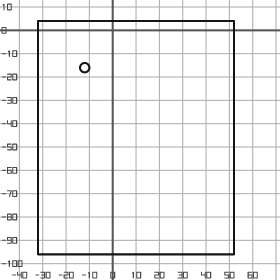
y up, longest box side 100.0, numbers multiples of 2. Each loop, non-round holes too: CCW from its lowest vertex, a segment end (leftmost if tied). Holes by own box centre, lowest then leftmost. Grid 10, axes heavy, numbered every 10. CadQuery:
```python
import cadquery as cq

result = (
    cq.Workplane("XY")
    .moveTo(-32.0, -96.0)
    .lineTo(52.0, -96.0)
    .lineTo(52.0, 4.0)
    .lineTo(-32.0, 4.0)
    .close()
    .moveTo(-12.0, -16.0)
    .circle(2.0)
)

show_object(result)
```